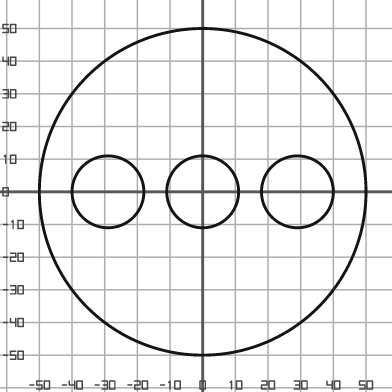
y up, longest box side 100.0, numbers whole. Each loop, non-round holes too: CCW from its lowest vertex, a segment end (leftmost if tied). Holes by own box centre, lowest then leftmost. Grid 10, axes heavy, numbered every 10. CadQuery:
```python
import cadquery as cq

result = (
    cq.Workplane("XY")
    .moveTo(0.0, 0.0)
    .circle(50.0)
    .moveTo(-29.0, 0.0)
    .circle(11.0)
    .moveTo(0.0, 0.0)
    .circle(11.0)
    .moveTo(29.0, 0.0)
    .circle(11.0)
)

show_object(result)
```